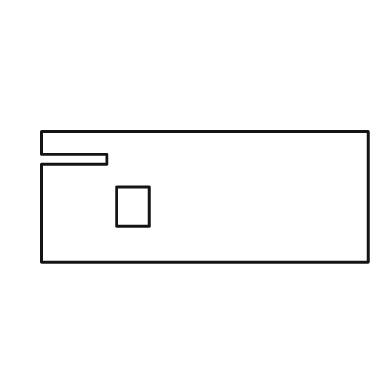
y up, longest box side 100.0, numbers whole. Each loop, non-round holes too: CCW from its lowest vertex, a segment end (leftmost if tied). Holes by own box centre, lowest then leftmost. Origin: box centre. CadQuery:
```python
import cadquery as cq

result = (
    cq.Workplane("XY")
    .moveTo(-50.0, -20.0)
    .lineTo(50.0, -20.0)
    .lineTo(50.0, 20.0)
    .lineTo(-50.0, 20.0)
    .lineTo(-50.0, 13.0)
    .lineTo(-30.0, 13.0)
    .lineTo(-30.0, 10.0)
    .lineTo(-50.0, 10.0)
    .close()
    .moveTo(-27.0, -9.0)
    .lineTo(-17.0, -9.0)
    .lineTo(-17.0, 3.0)
    .lineTo(-27.0, 3.0)
    .close()
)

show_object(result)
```